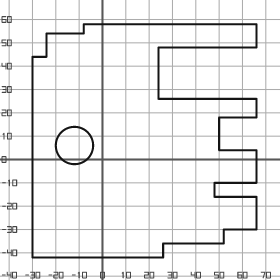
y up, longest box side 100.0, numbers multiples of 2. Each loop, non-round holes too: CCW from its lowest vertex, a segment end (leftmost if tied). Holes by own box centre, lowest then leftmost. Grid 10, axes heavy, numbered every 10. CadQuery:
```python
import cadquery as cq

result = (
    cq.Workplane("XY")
    .moveTo(-30.0, -42.0)
    .lineTo(26.0, -42.0)
    .lineTo(26.0, -36.0)
    .lineTo(52.0, -36.0)
    .lineTo(52.0, -30.0)
    .lineTo(66.0, -30.0)
    .lineTo(66.0, -16.0)
    .lineTo(48.0, -16.0)
    .lineTo(48.0, -10.0)
    .lineTo(66.0, -10.0)
    .lineTo(66.0, 4.0)
    .lineTo(50.0, 4.0)
    .lineTo(50.0, 18.0)
    .lineTo(66.0, 18.0)
    .lineTo(66.0, 26.0)
    .lineTo(24.0, 26.0)
    .lineTo(24.0, 48.0)
    .lineTo(66.0, 48.0)
    .lineTo(66.0, 58.0)
    .lineTo(-8.0, 58.0)
    .lineTo(-8.0, 54.0)
    .lineTo(-24.0, 54.0)
    .lineTo(-24.0, 44.0)
    .lineTo(-30.0, 44.0)
    .close()
    .moveTo(-12.0, 6.0)
    .circle(8.0)
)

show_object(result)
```